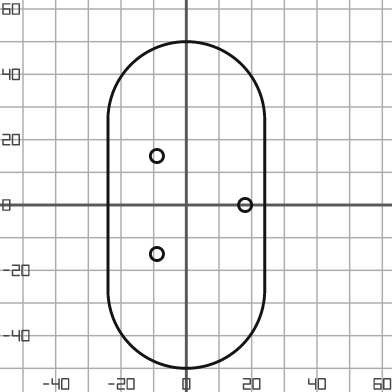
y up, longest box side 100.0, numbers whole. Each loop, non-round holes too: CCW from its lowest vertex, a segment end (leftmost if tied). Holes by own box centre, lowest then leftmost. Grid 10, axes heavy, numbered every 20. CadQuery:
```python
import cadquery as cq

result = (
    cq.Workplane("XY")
    .moveTo(-24.0, -26.0)
    .threePointArc((0.0, -50.0), (24.0, -26.0))
    .lineTo(24.0, 26.0)
    .threePointArc((0.0, 50.0), (-24.0, 26.0))
    .close()
    .moveTo(-9.0, -15.0)
    .circle(2.0)
    .moveTo(18.0, 0.0)
    .circle(2.0)
    .moveTo(-9.0, 15.0)
    .circle(2.0)
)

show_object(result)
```